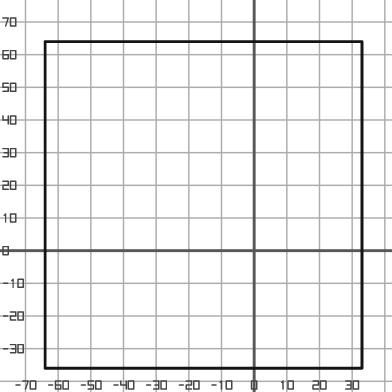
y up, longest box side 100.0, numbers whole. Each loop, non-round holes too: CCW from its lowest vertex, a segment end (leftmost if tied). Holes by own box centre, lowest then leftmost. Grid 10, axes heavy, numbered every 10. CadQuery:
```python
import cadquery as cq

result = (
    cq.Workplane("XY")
    .moveTo(-64.0, -36.0)
    .lineTo(33.0, -36.0)
    .lineTo(33.0, 64.0)
    .lineTo(-64.0, 64.0)
    .close()
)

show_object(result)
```